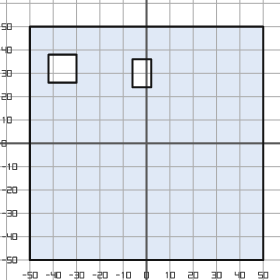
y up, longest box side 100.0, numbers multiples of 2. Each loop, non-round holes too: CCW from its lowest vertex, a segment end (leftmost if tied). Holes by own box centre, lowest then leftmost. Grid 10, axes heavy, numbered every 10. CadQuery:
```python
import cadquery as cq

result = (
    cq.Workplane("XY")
    .moveTo(-50.0, -50.0)
    .lineTo(50.0, -50.0)
    .lineTo(50.0, 50.0)
    .lineTo(-50.0, 50.0)
    .close()
    .moveTo(-6.0, 24.0)
    .lineTo(2.0, 24.0)
    .lineTo(2.0, 36.0)
    .lineTo(-6.0, 36.0)
    .close()
    .moveTo(-42.0, 26.0)
    .lineTo(-30.0, 26.0)
    .lineTo(-30.0, 38.0)
    .lineTo(-42.0, 38.0)
    .close()
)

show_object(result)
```